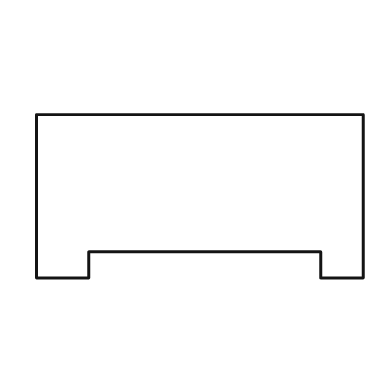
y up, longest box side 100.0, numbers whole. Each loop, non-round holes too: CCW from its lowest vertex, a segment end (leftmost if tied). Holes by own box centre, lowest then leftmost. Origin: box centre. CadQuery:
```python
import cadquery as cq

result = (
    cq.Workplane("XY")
    .moveTo(-50.0, -25.0)
    .lineTo(-34.0, -25.0)
    .lineTo(-34.0, -17.0)
    .lineTo(37.0, -17.0)
    .lineTo(37.0, -25.0)
    .lineTo(50.0, -25.0)
    .lineTo(50.0, 25.0)
    .lineTo(-50.0, 25.0)
    .close()
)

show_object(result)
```